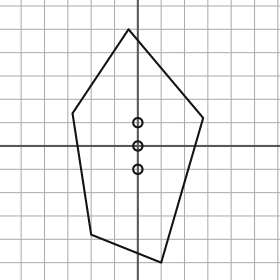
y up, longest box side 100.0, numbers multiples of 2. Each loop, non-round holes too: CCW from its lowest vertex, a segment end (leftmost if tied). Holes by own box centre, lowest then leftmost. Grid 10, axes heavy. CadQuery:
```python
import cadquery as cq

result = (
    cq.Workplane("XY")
    .moveTo(10.0, -50.0)
    .lineTo(28.0, 12.0)
    .lineTo(-4.0, 50.0)
    .lineTo(-28.0, 14.0)
    .lineTo(-20.0, -38.0)
    .close()
    .moveTo(0.0, -10.0)
    .circle(2.0)
    .moveTo(0.0, 0.0)
    .circle(2.0)
    .moveTo(0.0, 10.0)
    .circle(2.0)
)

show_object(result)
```